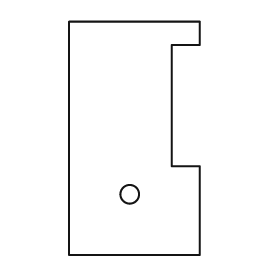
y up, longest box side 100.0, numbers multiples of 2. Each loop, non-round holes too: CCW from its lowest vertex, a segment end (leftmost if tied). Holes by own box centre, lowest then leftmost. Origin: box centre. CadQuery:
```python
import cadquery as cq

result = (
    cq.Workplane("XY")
    .moveTo(-28.0, -50.0)
    .lineTo(28.0, -50.0)
    .lineTo(28.0, -12.0)
    .lineTo(16.0, -12.0)
    .lineTo(16.0, 40.0)
    .lineTo(28.0, 40.0)
    .lineTo(28.0, 50.0)
    .lineTo(-28.0, 50.0)
    .close()
    .moveTo(-2.0, -24.0)
    .circle(4.0)
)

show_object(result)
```